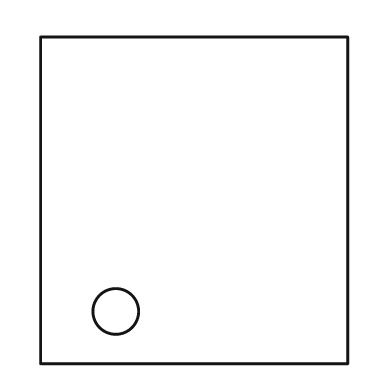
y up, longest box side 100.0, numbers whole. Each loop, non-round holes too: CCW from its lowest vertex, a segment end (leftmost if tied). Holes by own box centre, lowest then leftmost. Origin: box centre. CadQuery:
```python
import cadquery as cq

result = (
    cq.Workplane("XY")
    .moveTo(-47.0, -50.0)
    .lineTo(47.0, -50.0)
    .lineTo(47.0, 50.0)
    .lineTo(-47.0, 50.0)
    .close()
    .moveTo(-24.0, -34.0)
    .circle(7.0)
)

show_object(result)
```